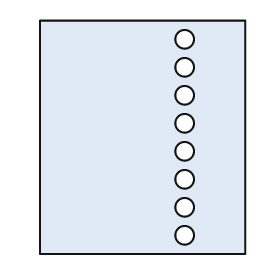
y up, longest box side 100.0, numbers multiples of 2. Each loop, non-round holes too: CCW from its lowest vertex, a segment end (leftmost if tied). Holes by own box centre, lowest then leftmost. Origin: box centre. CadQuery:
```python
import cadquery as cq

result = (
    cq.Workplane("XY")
    .moveTo(-44.0, -50.0)
    .lineTo(44.0, -50.0)
    .lineTo(44.0, 50.0)
    .lineTo(-44.0, 50.0)
    .close()
    .moveTo(18.0, -42.0)
    .circle(4.0)
    .moveTo(18.0, -30.0)
    .circle(4.0)
    .moveTo(18.0, -18.0)
    .circle(4.0)
    .moveTo(18.0, -6.0)
    .circle(4.0)
    .moveTo(18.0, 6.0)
    .circle(4.0)
    .moveTo(18.0, 18.0)
    .circle(4.0)
    .moveTo(18.0, 30.0)
    .circle(4.0)
    .moveTo(18.0, 42.0)
    .circle(4.0)
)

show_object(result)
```